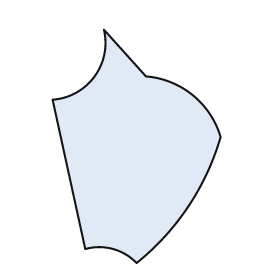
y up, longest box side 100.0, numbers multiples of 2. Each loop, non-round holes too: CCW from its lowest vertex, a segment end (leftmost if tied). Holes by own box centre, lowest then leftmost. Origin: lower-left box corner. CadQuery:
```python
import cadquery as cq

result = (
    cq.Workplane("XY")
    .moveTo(36.0, 0.0)
    .threePointArc((58.0, 24.0), (72.0, 54.0))
    .threePointArc((60.0, 72.0), (40.0, 80.0))
    .lineTo(22.0, 100.0)
    .threePointArc((18.0, 80.0), (0.0, 70.0))
    .lineTo(14.0, 6.0)
    .threePointArc((26.0, 6.0), (36.0, 0.0))
    .close()
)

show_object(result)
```